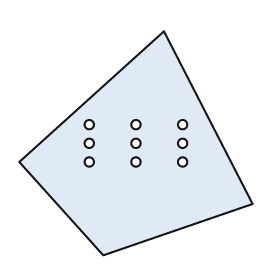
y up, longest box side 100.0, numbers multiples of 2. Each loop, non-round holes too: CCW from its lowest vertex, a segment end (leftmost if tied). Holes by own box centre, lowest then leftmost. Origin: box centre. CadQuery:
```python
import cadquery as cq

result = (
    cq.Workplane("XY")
    .moveTo(-14.0, -48.0)
    .lineTo(50.0, -26.0)
    .lineTo(12.0, 48.0)
    .lineTo(-50.0, -8.0)
    .close()
    .moveTo(-20.0, -8.0)
    .circle(2.0)
    .moveTo(0.0, -8.0)
    .circle(2.0)
    .moveTo(20.0, -8.0)
    .circle(2.0)
    .moveTo(-20.0, 0.0)
    .circle(2.0)
    .moveTo(0.0, 0.0)
    .circle(2.0)
    .moveTo(20.0, 0.0)
    .circle(2.0)
    .moveTo(-20.0, 8.0)
    .circle(2.0)
    .moveTo(0.0, 8.0)
    .circle(2.0)
    .moveTo(20.0, 8.0)
    .circle(2.0)
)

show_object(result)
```